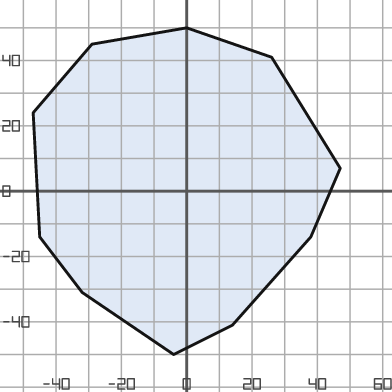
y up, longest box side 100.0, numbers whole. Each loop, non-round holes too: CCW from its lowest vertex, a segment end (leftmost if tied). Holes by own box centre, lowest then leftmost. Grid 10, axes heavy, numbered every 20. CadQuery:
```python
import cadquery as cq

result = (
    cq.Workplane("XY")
    .moveTo(-4.0, -50.0)
    .lineTo(14.0, -41.0)
    .lineTo(38.0, -14.0)
    .lineTo(47.0, 7.0)
    .lineTo(26.0, 41.0)
    .lineTo(0.0, 50.0)
    .lineTo(-29.0, 45.0)
    .lineTo(-47.0, 24.0)
    .lineTo(-45.0, -14.0)
    .lineTo(-32.0, -31.0)
    .close()
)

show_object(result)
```